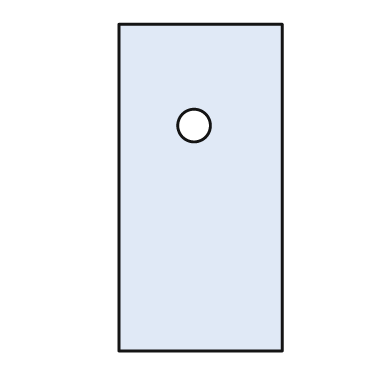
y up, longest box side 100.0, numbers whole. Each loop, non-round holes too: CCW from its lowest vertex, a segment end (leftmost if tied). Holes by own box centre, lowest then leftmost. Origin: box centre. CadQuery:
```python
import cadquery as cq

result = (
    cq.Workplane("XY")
    .moveTo(-25.0, -50.0)
    .lineTo(25.0, -50.0)
    .lineTo(25.0, 50.0)
    .lineTo(-25.0, 50.0)
    .close()
    .moveTo(-2.0, 19.0)
    .circle(5.0)
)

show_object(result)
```